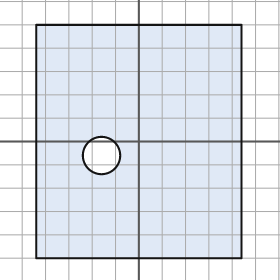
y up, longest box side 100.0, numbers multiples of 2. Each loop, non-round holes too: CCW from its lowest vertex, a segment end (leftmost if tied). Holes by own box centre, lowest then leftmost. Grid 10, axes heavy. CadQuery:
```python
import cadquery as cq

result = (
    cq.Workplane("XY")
    .moveTo(-44.0, -50.0)
    .lineTo(44.0, -50.0)
    .lineTo(44.0, 50.0)
    .lineTo(-44.0, 50.0)
    .close()
    .moveTo(-16.0, -6.0)
    .circle(8.0)
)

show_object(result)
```